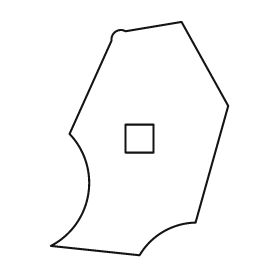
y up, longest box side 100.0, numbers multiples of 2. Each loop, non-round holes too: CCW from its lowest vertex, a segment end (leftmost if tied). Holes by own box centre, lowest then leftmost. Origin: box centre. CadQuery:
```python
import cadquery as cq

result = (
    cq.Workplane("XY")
    .moveTo(0.0, -50.0)
    .threePointArc((10.0, -40.0), (24.0, -36.0))
    .lineTo(38.0, 14.0)
    .lineTo(18.0, 50.0)
    .lineTo(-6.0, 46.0)
    .threePointArc((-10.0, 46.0), (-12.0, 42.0))
    .lineTo(-30.0, 2.0)
    .threePointArc((-22.0, -24.0), (-38.0, -46.0))
    .close()
    .moveTo(-6.0, -6.0)
    .lineTo(6.0, -6.0)
    .lineTo(6.0, 6.0)
    .lineTo(-6.0, 6.0)
    .close()
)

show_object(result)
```